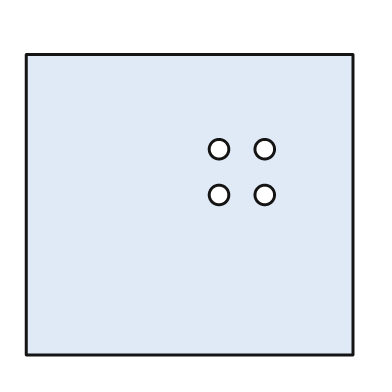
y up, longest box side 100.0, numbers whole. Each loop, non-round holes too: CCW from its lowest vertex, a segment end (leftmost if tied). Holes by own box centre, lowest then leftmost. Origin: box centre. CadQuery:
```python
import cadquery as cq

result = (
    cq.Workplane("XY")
    .moveTo(-50.0, -46.0)
    .lineTo(50.0, -46.0)
    .lineTo(50.0, 46.0)
    .lineTo(-50.0, 46.0)
    .close()
    .moveTo(9.0, 3.0)
    .circle(3.0)
    .moveTo(23.0, 3.0)
    .circle(3.0)
    .moveTo(9.0, 17.0)
    .circle(3.0)
    .moveTo(23.0, 17.0)
    .circle(3.0)
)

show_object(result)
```